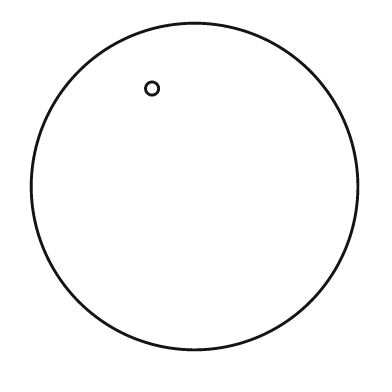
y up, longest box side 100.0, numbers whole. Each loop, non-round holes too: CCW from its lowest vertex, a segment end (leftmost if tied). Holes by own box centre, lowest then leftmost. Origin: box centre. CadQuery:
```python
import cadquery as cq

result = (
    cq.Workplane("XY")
    .moveTo(0.0, 0.0)
    .circle(50.0)
    .moveTo(-13.0, 30.0)
    .circle(2.0)
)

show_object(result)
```